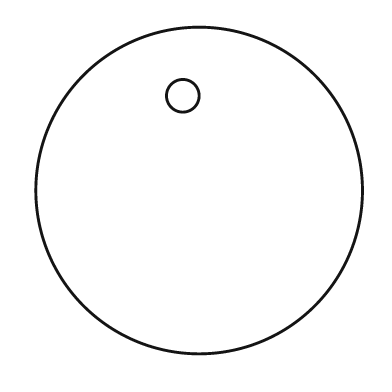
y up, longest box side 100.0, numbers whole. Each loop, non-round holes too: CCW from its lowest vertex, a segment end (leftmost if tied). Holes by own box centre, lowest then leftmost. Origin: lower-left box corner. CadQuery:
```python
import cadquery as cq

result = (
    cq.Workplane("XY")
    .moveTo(50.0, 50.0)
    .circle(50.0)
    .moveTo(45.0, 79.0)
    .circle(5.0)
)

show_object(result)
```